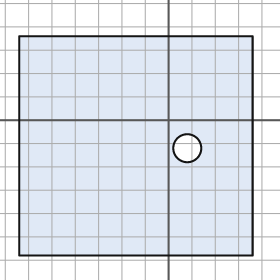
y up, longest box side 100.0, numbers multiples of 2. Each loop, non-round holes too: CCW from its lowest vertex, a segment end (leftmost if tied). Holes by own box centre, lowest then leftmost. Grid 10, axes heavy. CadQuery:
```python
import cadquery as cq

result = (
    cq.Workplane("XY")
    .moveTo(-64.0, -58.0)
    .lineTo(36.0, -58.0)
    .lineTo(36.0, 36.0)
    .lineTo(-64.0, 36.0)
    .close()
    .moveTo(8.0, -12.0)
    .circle(6.0)
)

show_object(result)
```